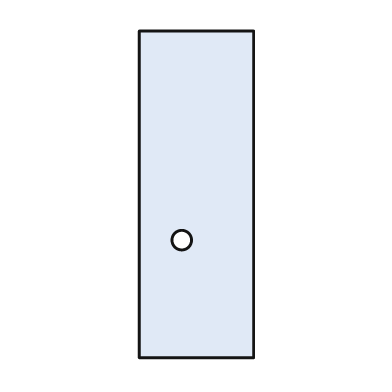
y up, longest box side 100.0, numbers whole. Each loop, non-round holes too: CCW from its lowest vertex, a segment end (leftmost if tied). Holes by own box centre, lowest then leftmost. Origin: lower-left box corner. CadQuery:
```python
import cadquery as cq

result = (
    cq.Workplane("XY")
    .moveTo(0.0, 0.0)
    .lineTo(35.0, 0.0)
    .lineTo(35.0, 100.0)
    .lineTo(0.0, 100.0)
    .close()
    .moveTo(13.0, 36.0)
    .circle(3.0)
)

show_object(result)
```